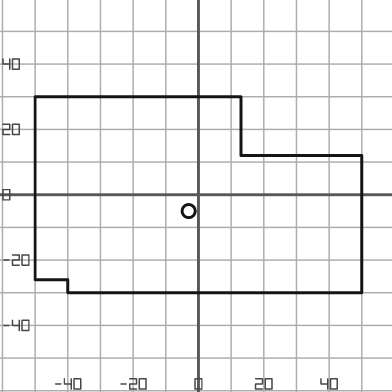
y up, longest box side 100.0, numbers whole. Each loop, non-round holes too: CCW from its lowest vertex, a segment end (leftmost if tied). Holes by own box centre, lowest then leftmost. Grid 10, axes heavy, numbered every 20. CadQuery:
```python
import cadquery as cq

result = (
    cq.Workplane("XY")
    .moveTo(-40.0, -30.0)
    .lineTo(50.0, -30.0)
    .lineTo(50.0, 12.0)
    .lineTo(13.0, 12.0)
    .lineTo(13.0, 30.0)
    .lineTo(-50.0, 30.0)
    .lineTo(-50.0, -26.0)
    .lineTo(-40.0, -26.0)
    .close()
    .moveTo(-3.0, -5.0)
    .circle(2.0)
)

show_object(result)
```